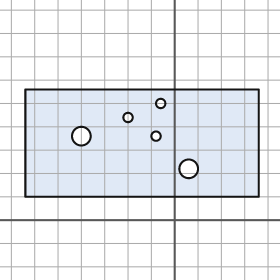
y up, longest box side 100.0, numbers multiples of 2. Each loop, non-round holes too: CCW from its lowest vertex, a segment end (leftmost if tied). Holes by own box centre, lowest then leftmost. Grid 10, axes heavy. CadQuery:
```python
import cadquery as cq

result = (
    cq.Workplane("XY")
    .moveTo(-64.0, 10.0)
    .lineTo(36.0, 10.0)
    .lineTo(36.0, 56.0)
    .lineTo(-64.0, 56.0)
    .close()
    .moveTo(6.0, 22.0)
    .circle(4.0)
    .moveTo(-40.0, 36.0)
    .circle(4.0)
    .moveTo(-8.0, 36.0)
    .circle(2.0)
    .moveTo(-20.0, 44.0)
    .circle(2.0)
    .moveTo(-6.0, 50.0)
    .circle(2.0)
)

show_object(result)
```